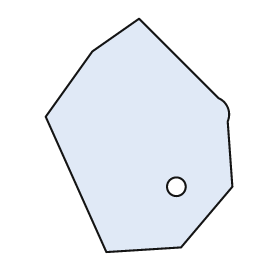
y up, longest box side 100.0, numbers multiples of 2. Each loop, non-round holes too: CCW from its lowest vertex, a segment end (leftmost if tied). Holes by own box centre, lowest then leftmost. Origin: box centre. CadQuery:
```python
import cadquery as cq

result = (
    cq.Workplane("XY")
    .moveTo(-14.0, -50.0)
    .lineTo(18.0, -48.0)
    .lineTo(40.0, -22.0)
    .lineTo(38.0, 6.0)
    .threePointArc((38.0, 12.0), (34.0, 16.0))
    .lineTo(0.0, 50.0)
    .lineTo(-20.0, 36.0)
    .lineTo(-40.0, 8.0)
    .close()
    .moveTo(16.0, -22.0)
    .circle(4.0)
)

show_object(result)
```